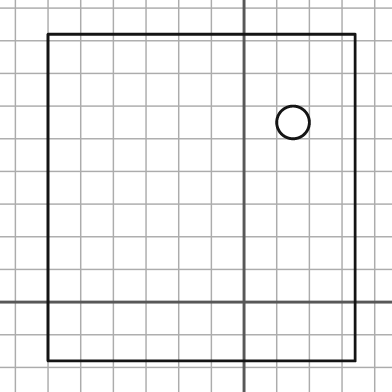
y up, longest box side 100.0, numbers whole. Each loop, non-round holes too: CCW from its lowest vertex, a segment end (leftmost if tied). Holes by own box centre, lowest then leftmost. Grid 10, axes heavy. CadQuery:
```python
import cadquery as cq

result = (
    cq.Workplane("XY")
    .moveTo(-60.0, -18.0)
    .lineTo(34.0, -18.0)
    .lineTo(34.0, 82.0)
    .lineTo(-60.0, 82.0)
    .close()
    .moveTo(15.0, 55.0)
    .circle(5.0)
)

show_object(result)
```